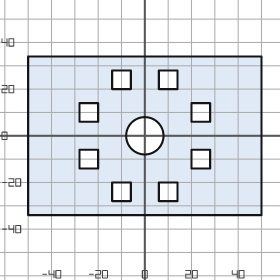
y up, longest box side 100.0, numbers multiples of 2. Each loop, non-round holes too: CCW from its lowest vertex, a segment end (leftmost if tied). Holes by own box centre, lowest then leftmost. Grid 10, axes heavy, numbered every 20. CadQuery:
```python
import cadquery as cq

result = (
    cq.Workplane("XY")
    .moveTo(-50.0, -34.0)
    .lineTo(50.0, -34.0)
    .lineTo(50.0, 34.0)
    .lineTo(-50.0, 34.0)
    .close()
    .moveTo(-14.0, -28.0)
    .lineTo(-6.0, -28.0)
    .lineTo(-6.0, -20.0)
    .lineTo(-14.0, -20.0)
    .close()
    .moveTo(6.0, -28.0)
    .lineTo(14.0, -28.0)
    .lineTo(14.0, -20.0)
    .lineTo(6.0, -20.0)
    .close()
    .moveTo(-28.0, -14.0)
    .lineTo(-20.0, -14.0)
    .lineTo(-20.0, -6.0)
    .lineTo(-28.0, -6.0)
    .close()
    .moveTo(20.0, -14.0)
    .lineTo(28.0, -14.0)
    .lineTo(28.0, -6.0)
    .lineTo(20.0, -6.0)
    .close()
    .moveTo(0.0, 0.0)
    .circle(8.0)
    .moveTo(-28.0, 6.0)
    .lineTo(-20.0, 6.0)
    .lineTo(-20.0, 14.0)
    .lineTo(-28.0, 14.0)
    .close()
    .moveTo(20.0, 6.0)
    .lineTo(28.0, 6.0)
    .lineTo(28.0, 14.0)
    .lineTo(20.0, 14.0)
    .close()
    .moveTo(-14.0, 20.0)
    .lineTo(-6.0, 20.0)
    .lineTo(-6.0, 28.0)
    .lineTo(-14.0, 28.0)
    .close()
    .moveTo(6.0, 20.0)
    .lineTo(14.0, 20.0)
    .lineTo(14.0, 28.0)
    .lineTo(6.0, 28.0)
    .close()
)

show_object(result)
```